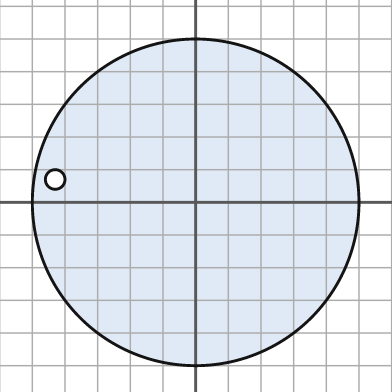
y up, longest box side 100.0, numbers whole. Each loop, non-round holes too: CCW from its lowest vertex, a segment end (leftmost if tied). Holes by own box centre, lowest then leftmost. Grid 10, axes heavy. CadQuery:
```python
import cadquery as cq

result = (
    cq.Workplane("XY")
    .moveTo(0.0, 0.0)
    .circle(50.0)
    .moveTo(-43.0, 7.0)
    .circle(3.0)
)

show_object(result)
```